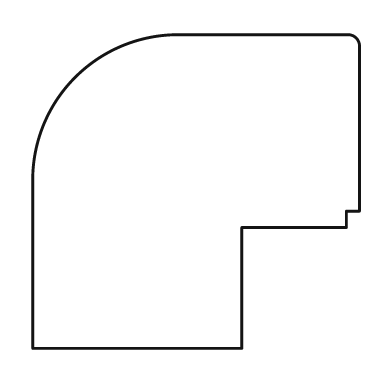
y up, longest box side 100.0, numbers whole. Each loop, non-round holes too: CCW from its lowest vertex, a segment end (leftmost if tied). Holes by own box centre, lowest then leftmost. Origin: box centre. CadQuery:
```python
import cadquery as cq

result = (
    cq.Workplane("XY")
    .moveTo(-50.0, -48.0)
    .lineTo(14.0, -48.0)
    .lineTo(14.0, -11.0)
    .lineTo(46.0, -11.0)
    .lineTo(46.0, -6.0)
    .lineTo(50.0, -6.0)
    .lineTo(50.0, 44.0)
    .threePointArc((49.0, 47.0), (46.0, 48.0))
    .lineTo(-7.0, 48.0)
    .threePointArc((-37.0, 35.0), (-50.0, 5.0))
    .close()
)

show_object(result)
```